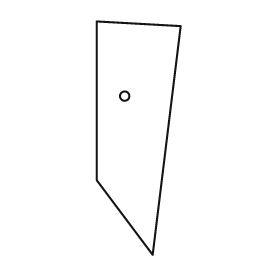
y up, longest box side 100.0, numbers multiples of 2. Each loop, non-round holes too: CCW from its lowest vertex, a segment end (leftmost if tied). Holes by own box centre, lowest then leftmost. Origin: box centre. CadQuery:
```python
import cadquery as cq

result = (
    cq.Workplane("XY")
    .moveTo(6.0, -50.0)
    .lineTo(18.0, 48.0)
    .lineTo(-18.0, 50.0)
    .lineTo(-18.0, -18.0)
    .close()
    .moveTo(-6.0, 18.0)
    .circle(2.0)
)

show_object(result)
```